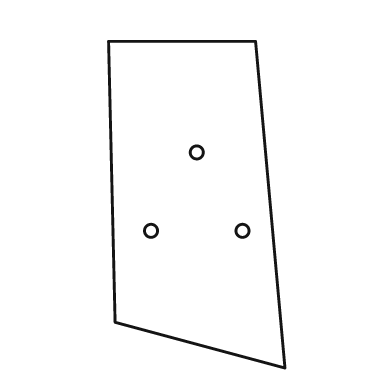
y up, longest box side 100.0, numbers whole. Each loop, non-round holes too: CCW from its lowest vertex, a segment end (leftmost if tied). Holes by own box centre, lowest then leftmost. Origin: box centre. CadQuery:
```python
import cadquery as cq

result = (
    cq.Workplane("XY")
    .moveTo(27.0, -50.0)
    .lineTo(18.0, 50.0)
    .lineTo(-27.0, 50.0)
    .lineTo(-25.0, -36.0)
    .close()
    .moveTo(-14.0, -8.0)
    .circle(2.0)
    .moveTo(14.0, -8.0)
    .circle(2.0)
    .moveTo(0.0, 16.0)
    .circle(2.0)
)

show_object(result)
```